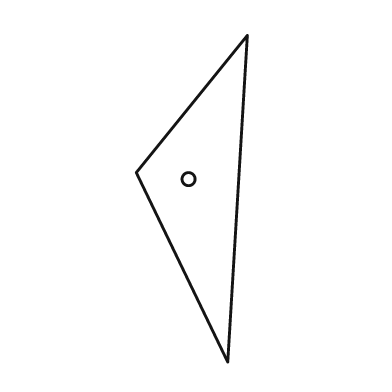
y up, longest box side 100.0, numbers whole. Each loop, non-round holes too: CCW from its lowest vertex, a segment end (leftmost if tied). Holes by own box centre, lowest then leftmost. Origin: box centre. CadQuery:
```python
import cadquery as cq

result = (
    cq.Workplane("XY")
    .moveTo(11.0, -50.0)
    .lineTo(17.0, 50.0)
    .lineTo(-17.0, 8.0)
    .close()
    .moveTo(-1.0, 6.0)
    .circle(2.0)
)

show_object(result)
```